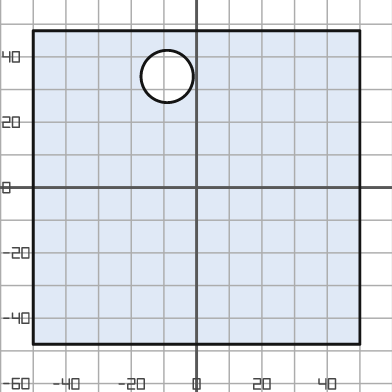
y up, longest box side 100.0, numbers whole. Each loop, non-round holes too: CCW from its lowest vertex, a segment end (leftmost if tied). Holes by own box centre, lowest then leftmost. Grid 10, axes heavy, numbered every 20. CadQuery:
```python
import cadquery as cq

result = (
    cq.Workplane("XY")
    .moveTo(-50.0, -48.0)
    .lineTo(50.0, -48.0)
    .lineTo(50.0, 48.0)
    .lineTo(-50.0, 48.0)
    .close()
    .moveTo(-9.0, 34.0)
    .circle(8.0)
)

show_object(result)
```